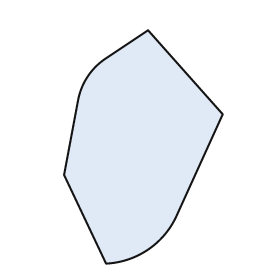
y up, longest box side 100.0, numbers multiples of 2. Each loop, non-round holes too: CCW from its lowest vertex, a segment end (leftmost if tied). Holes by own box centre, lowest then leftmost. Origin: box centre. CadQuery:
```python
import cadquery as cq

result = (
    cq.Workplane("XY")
    .moveTo(-16.0, -50.0)
    .threePointArc((2.0, -44.0), (14.0, -30.0))
    .lineTo(34.0, 14.0)
    .lineTo(2.0, 50.0)
    .lineTo(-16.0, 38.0)
    .threePointArc((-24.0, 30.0), (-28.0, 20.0))
    .lineTo(-34.0, -12.0)
    .close()
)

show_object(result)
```